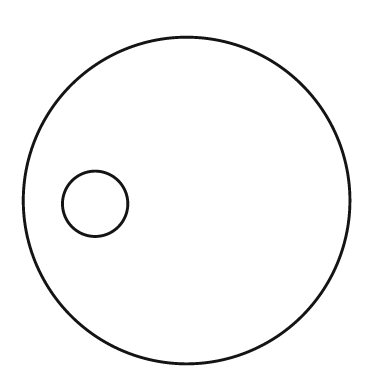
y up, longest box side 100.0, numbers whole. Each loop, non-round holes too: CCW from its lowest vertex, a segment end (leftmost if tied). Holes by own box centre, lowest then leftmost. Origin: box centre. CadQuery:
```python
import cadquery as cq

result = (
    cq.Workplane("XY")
    .moveTo(0.0, 0.0)
    .circle(50.0)
    .moveTo(-28.0, -1.0)
    .circle(10.0)
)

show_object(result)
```